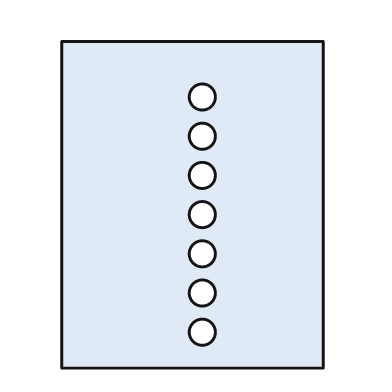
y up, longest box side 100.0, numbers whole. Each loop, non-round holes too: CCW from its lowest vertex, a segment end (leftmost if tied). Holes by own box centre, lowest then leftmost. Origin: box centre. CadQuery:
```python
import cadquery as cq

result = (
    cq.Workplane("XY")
    .moveTo(-40.0, -50.0)
    .lineTo(40.0, -50.0)
    .lineTo(40.0, 50.0)
    .lineTo(-40.0, 50.0)
    .close()
    .moveTo(3.0, -39.0)
    .circle(4.0)
    .moveTo(3.0, -27.0)
    .circle(4.0)
    .moveTo(3.0, -15.0)
    .circle(4.0)
    .moveTo(3.0, -3.0)
    .circle(4.0)
    .moveTo(3.0, 9.0)
    .circle(4.0)
    .moveTo(3.0, 21.0)
    .circle(4.0)
    .moveTo(3.0, 33.0)
    .circle(4.0)
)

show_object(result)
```